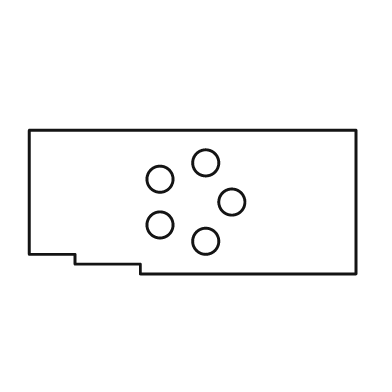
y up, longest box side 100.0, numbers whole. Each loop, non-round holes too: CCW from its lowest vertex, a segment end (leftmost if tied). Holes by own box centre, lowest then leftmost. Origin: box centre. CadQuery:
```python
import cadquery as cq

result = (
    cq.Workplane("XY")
    .moveTo(-16.0, -22.0)
    .lineTo(50.0, -22.0)
    .lineTo(50.0, 22.0)
    .lineTo(-50.0, 22.0)
    .lineTo(-50.0, -16.0)
    .lineTo(-36.0, -16.0)
    .lineTo(-36.0, -19.0)
    .lineTo(-16.0, -19.0)
    .close()
    .moveTo(4.0, -12.0)
    .circle(4.0)
    .moveTo(-10.0, -7.0)
    .circle(4.0)
    .moveTo(12.0, 0.0)
    .circle(4.0)
    .moveTo(-10.0, 7.0)
    .circle(4.0)
    .moveTo(4.0, 12.0)
    .circle(4.0)
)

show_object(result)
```